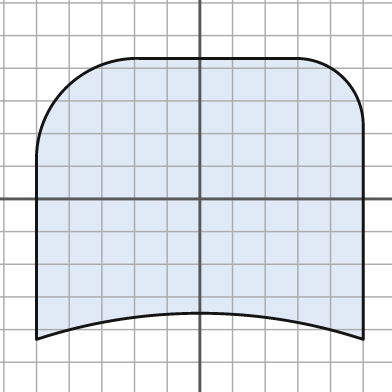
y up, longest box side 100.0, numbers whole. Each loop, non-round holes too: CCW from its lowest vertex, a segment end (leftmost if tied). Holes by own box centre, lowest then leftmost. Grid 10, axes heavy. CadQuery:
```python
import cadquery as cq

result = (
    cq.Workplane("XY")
    .moveTo(-50.0, -43.0)
    .threePointArc((0.0, -35.0), (50.0, -43.0))
    .lineTo(50.0, 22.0)
    .threePointArc((44.0, 37.0), (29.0, 43.0))
    .lineTo(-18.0, 43.0)
    .threePointArc((-41.0, 34.0), (-50.0, 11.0))
    .close()
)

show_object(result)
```